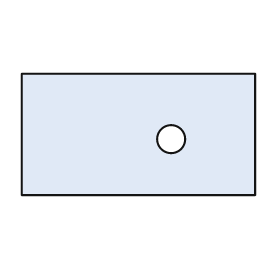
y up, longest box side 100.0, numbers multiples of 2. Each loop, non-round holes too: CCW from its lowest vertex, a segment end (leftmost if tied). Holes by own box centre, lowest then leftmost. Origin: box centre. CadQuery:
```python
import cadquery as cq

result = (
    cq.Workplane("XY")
    .moveTo(-50.0, -26.0)
    .lineTo(50.0, -26.0)
    .lineTo(50.0, 26.0)
    .lineTo(-50.0, 26.0)
    .close()
    .moveTo(14.0, -2.0)
    .circle(6.0)
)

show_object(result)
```